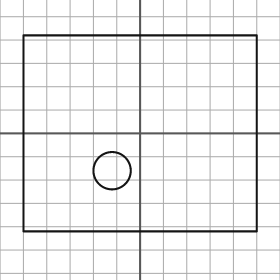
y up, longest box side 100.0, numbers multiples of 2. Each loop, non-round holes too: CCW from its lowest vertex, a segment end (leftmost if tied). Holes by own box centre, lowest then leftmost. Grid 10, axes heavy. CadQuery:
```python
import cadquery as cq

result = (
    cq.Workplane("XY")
    .moveTo(-50.0, -42.0)
    .lineTo(50.0, -42.0)
    .lineTo(50.0, 42.0)
    .lineTo(-50.0, 42.0)
    .close()
    .moveTo(-12.0, -16.0)
    .circle(8.0)
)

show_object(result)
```